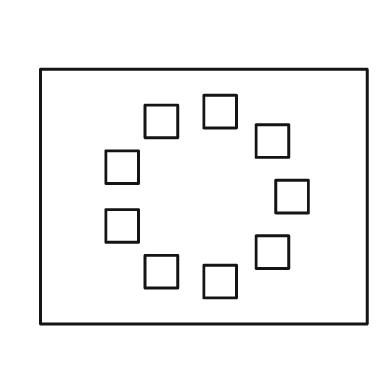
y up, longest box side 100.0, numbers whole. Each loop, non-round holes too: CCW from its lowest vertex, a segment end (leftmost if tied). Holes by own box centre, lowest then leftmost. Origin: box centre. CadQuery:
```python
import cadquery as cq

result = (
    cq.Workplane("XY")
    .moveTo(-50.0, -39.0)
    .lineTo(50.0, -39.0)
    .lineTo(50.0, 39.0)
    .lineTo(-50.0, 39.0)
    .close()
    .moveTo(0.0, -31.0)
    .lineTo(10.0, -31.0)
    .lineTo(10.0, -21.0)
    .lineTo(0.0, -21.0)
    .close()
    .moveTo(-18.0, -28.0)
    .lineTo(-8.0, -28.0)
    .lineTo(-8.0, -18.0)
    .lineTo(-18.0, -18.0)
    .close()
    .moveTo(16.0, -22.0)
    .lineTo(26.0, -22.0)
    .lineTo(26.0, -12.0)
    .lineTo(16.0, -12.0)
    .close()
    .moveTo(-30.0, -14.0)
    .lineTo(-20.0, -14.0)
    .lineTo(-20.0, -4.0)
    .lineTo(-30.0, -4.0)
    .close()
    .moveTo(22.0, -5.0)
    .lineTo(32.0, -5.0)
    .lineTo(32.0, 5.0)
    .lineTo(22.0, 5.0)
    .close()
    .moveTo(-30.0, 4.0)
    .lineTo(-20.0, 4.0)
    .lineTo(-20.0, 14.0)
    .lineTo(-30.0, 14.0)
    .close()
    .moveTo(16.0, 12.0)
    .lineTo(26.0, 12.0)
    .lineTo(26.0, 22.0)
    .lineTo(16.0, 22.0)
    .close()
    .moveTo(-18.0, 18.0)
    .lineTo(-8.0, 18.0)
    .lineTo(-8.0, 28.0)
    .lineTo(-18.0, 28.0)
    .close()
    .moveTo(0.0, 21.0)
    .lineTo(10.0, 21.0)
    .lineTo(10.0, 31.0)
    .lineTo(0.0, 31.0)
    .close()
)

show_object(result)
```